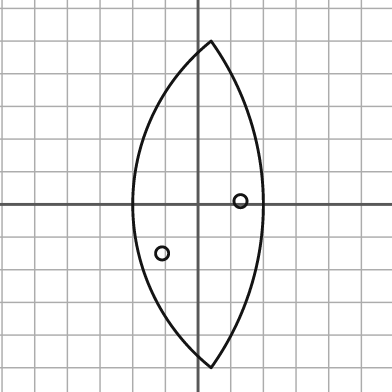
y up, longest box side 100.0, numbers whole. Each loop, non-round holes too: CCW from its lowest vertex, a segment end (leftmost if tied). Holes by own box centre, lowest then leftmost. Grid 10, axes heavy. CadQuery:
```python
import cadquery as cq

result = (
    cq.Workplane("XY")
    .moveTo(4.0, -50.0)
    .threePointArc((20.0, 0.0), (4.0, 50.0))
    .threePointArc((-20.0, 0.0), (4.0, -50.0))
    .close()
    .moveTo(-11.0, -15.0)
    .circle(2.0)
    .moveTo(13.0, 1.0)
    .circle(2.0)
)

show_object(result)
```